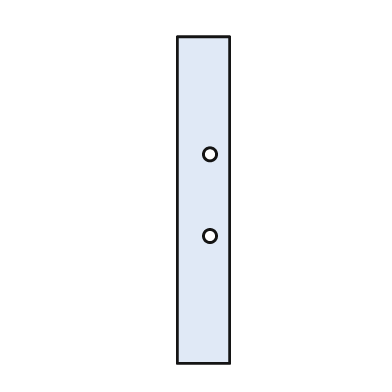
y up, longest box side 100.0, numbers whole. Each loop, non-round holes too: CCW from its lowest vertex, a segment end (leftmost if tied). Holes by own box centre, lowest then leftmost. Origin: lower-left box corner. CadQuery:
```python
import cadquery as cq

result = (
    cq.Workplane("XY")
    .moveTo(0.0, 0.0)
    .lineTo(16.0, 0.0)
    .lineTo(16.0, 100.0)
    .lineTo(0.0, 100.0)
    .close()
    .moveTo(10.0, 39.0)
    .circle(2.0)
    .moveTo(10.0, 64.0)
    .circle(2.0)
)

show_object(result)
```